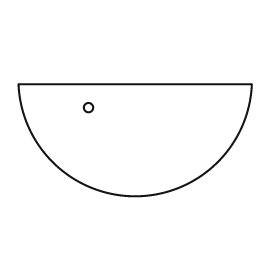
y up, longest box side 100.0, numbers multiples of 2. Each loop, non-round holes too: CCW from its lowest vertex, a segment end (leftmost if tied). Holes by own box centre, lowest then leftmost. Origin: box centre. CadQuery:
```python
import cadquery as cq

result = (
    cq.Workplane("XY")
    .moveTo(-50.0, 24.0)
    .threePointArc((0.0, -24.0), (50.0, 24.0))
    .close()
    .moveTo(-20.0, 14.0)
    .circle(2.0)
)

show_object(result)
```